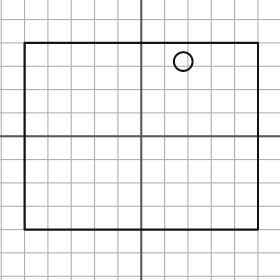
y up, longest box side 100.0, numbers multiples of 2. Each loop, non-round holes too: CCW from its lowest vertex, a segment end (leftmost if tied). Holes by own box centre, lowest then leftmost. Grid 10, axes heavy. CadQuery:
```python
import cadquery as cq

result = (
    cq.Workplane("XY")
    .moveTo(-50.0, -40.0)
    .lineTo(50.0, -40.0)
    .lineTo(50.0, 40.0)
    .lineTo(-50.0, 40.0)
    .close()
    .moveTo(18.0, 32.0)
    .circle(4.0)
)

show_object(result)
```